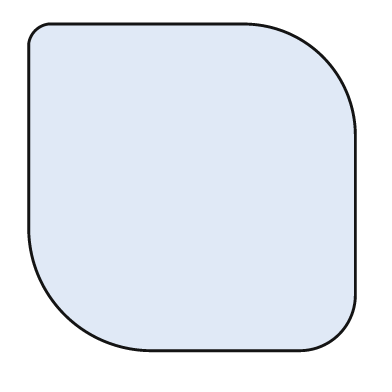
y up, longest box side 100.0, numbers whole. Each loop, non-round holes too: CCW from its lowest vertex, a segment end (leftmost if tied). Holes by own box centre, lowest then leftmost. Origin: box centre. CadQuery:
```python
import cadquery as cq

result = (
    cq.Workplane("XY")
    .moveTo(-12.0, -50.0)
    .lineTo(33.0, -50.0)
    .threePointArc((45.0, -45.0), (50.0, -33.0))
    .lineTo(50.0, 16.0)
    .threePointArc((40.0, 40.0), (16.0, 50.0))
    .lineTo(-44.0, 50.0)
    .threePointArc((-48.0, 48.0), (-50.0, 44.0))
    .lineTo(-50.0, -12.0)
    .threePointArc((-39.0, -39.0), (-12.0, -50.0))
    .close()
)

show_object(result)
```